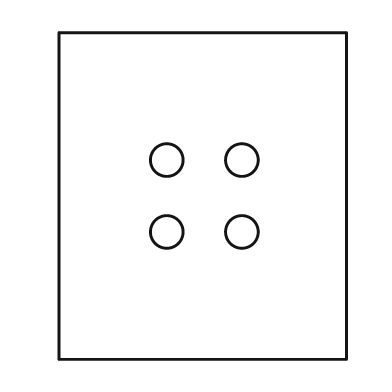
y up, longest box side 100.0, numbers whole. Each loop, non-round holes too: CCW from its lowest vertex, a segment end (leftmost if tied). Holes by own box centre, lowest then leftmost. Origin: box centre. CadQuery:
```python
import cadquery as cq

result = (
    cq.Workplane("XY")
    .moveTo(-44.0, -50.0)
    .lineTo(44.0, -50.0)
    .lineTo(44.0, 50.0)
    .lineTo(-44.0, 50.0)
    .close()
    .moveTo(-11.0, -11.0)
    .circle(5.0)
    .moveTo(12.0, -11.0)
    .circle(5.0)
    .moveTo(-11.0, 11.0)
    .circle(5.0)
    .moveTo(12.0, 11.0)
    .circle(5.0)
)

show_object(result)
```